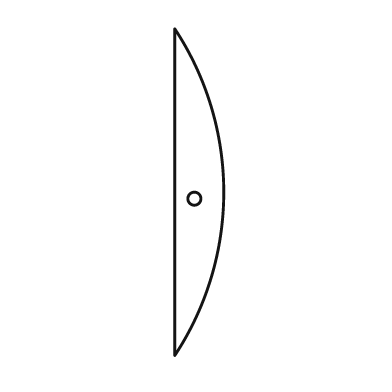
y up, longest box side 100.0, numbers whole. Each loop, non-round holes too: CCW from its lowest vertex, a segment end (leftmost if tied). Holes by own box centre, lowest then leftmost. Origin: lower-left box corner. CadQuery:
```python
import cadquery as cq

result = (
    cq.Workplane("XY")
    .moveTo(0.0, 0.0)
    .threePointArc((15.0, 50.0), (0.0, 100.0))
    .close()
    .moveTo(6.0, 48.0)
    .circle(2.0)
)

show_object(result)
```